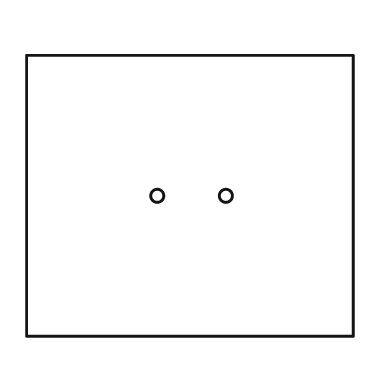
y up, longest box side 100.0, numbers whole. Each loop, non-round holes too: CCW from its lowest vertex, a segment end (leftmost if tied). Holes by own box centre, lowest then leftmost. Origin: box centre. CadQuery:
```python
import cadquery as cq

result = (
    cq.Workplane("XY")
    .moveTo(-50.0, -43.0)
    .lineTo(50.0, -43.0)
    .lineTo(50.0, 43.0)
    .lineTo(-50.0, 43.0)
    .close()
    .moveTo(-10.0, 0.0)
    .circle(2.0)
    .moveTo(11.0, 0.0)
    .circle(2.0)
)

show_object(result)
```